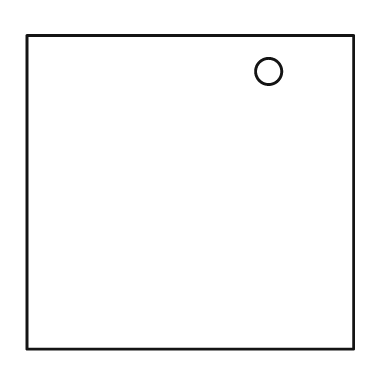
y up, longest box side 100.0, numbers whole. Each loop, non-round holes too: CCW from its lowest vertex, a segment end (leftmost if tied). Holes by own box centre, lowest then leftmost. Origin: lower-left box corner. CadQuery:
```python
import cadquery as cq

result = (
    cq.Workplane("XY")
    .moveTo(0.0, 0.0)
    .lineTo(100.0, 0.0)
    .lineTo(100.0, 96.0)
    .lineTo(0.0, 96.0)
    .close()
    .moveTo(74.0, 85.0)
    .circle(4.0)
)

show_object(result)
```